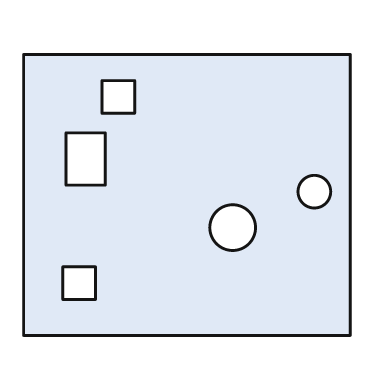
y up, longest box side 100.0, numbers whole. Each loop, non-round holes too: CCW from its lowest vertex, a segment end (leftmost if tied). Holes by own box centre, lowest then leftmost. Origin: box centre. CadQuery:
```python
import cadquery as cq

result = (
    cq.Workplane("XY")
    .moveTo(-50.0, -43.0)
    .lineTo(50.0, -43.0)
    .lineTo(50.0, 43.0)
    .lineTo(-50.0, 43.0)
    .close()
    .moveTo(-38.0, -32.0)
    .lineTo(-28.0, -32.0)
    .lineTo(-28.0, -22.0)
    .lineTo(-38.0, -22.0)
    .close()
    .moveTo(14.0, -10.0)
    .circle(7.0)
    .moveTo(39.0, 1.0)
    .circle(5.0)
    .moveTo(-37.0, 3.0)
    .lineTo(-25.0, 3.0)
    .lineTo(-25.0, 19.0)
    .lineTo(-37.0, 19.0)
    .close()
    .moveTo(-26.0, 25.0)
    .lineTo(-16.0, 25.0)
    .lineTo(-16.0, 35.0)
    .lineTo(-26.0, 35.0)
    .close()
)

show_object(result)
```